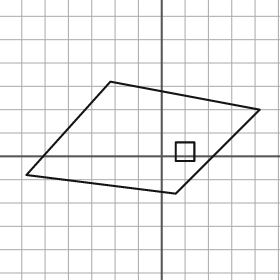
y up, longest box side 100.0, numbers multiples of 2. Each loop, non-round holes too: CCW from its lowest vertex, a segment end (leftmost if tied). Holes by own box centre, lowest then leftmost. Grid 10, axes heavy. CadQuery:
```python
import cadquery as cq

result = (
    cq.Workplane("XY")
    .moveTo(6.0, -16.0)
    .lineTo(42.0, 20.0)
    .lineTo(-22.0, 32.0)
    .lineTo(-58.0, -8.0)
    .close()
    .moveTo(6.0, -2.0)
    .lineTo(14.0, -2.0)
    .lineTo(14.0, 6.0)
    .lineTo(6.0, 6.0)
    .close()
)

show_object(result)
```